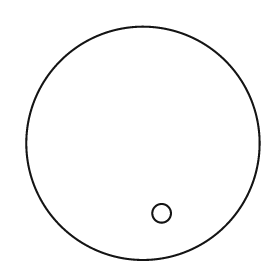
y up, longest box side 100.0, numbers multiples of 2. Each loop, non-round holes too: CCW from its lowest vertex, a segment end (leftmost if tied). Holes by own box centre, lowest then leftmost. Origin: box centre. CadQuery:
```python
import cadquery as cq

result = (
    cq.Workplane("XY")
    .moveTo(0.0, 0.0)
    .circle(50.0)
    .moveTo(8.0, -30.0)
    .circle(4.0)
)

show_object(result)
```